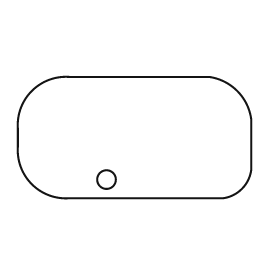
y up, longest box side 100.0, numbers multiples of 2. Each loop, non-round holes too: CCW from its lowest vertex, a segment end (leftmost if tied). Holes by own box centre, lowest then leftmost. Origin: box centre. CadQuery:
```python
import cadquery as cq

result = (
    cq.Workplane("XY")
    .moveTo(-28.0, -26.0)
    .lineTo(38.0, -26.0)
    .threePointArc((46.0, -22.0), (50.0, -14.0))
    .lineTo(50.0, 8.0)
    .threePointArc((44.0, 20.0), (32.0, 26.0))
    .lineTo(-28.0, 26.0)
    .threePointArc((-44.0, 20.0), (-50.0, 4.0))
    .lineTo(-50.0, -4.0)
    .threePointArc((-44.0, -20.0), (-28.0, -26.0))
    .close()
    .moveTo(-12.0, -18.0)
    .circle(4.0)
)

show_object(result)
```